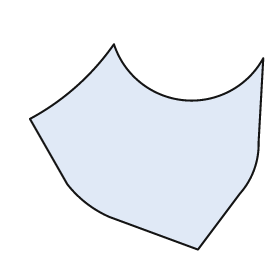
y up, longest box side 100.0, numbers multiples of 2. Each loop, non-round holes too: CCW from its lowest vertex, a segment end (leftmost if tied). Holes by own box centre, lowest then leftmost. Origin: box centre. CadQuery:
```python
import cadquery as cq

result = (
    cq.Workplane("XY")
    .moveTo(22.0, -44.0)
    .lineTo(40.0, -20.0)
    .threePointArc((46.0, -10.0), (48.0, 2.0))
    .lineTo(50.0, 38.0)
    .threePointArc((16.0, 20.0), (-14.0, 44.0))
    .threePointArc((-30.0, 26.0), (-50.0, 12.0))
    .lineTo(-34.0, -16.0)
    .threePointArc((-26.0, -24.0), (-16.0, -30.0))
    .close()
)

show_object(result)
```